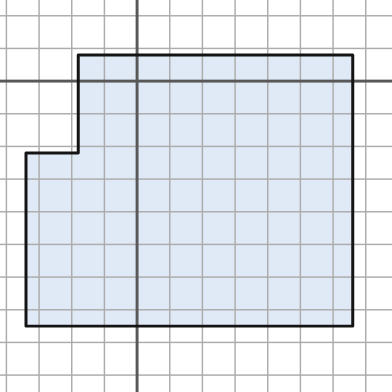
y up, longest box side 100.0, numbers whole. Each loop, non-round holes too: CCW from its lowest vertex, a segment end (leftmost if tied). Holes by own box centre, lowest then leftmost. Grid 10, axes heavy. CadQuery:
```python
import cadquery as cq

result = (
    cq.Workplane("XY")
    .moveTo(-34.0, -75.0)
    .lineTo(66.0, -75.0)
    .lineTo(66.0, 8.0)
    .lineTo(-18.0, 8.0)
    .lineTo(-18.0, -22.0)
    .lineTo(-34.0, -22.0)
    .close()
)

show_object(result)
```